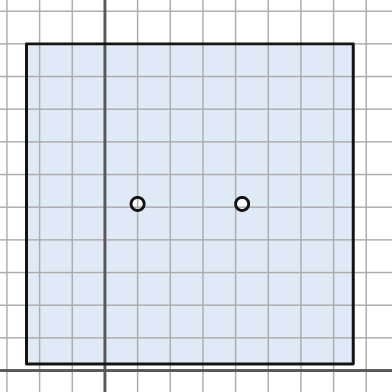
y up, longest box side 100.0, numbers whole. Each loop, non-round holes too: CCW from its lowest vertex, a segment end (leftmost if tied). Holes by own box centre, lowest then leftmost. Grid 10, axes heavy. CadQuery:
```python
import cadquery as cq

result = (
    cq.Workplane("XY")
    .moveTo(-24.0, 2.0)
    .lineTo(76.0, 2.0)
    .lineTo(76.0, 100.0)
    .lineTo(-24.0, 100.0)
    .close()
    .moveTo(10.0, 51.0)
    .circle(2.0)
    .moveTo(42.0, 51.0)
    .circle(2.0)
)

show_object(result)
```